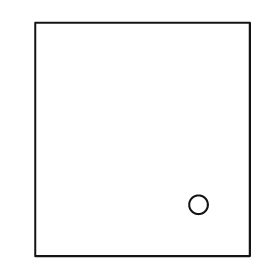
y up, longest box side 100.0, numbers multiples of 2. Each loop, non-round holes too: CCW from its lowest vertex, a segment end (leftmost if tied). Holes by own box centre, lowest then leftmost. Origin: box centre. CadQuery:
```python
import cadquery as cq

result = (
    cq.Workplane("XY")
    .moveTo(-46.0, -50.0)
    .lineTo(46.0, -50.0)
    .lineTo(46.0, 50.0)
    .lineTo(-46.0, 50.0)
    .close()
    .moveTo(24.0, -28.0)
    .circle(4.0)
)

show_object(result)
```